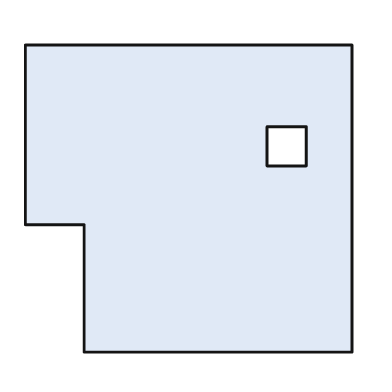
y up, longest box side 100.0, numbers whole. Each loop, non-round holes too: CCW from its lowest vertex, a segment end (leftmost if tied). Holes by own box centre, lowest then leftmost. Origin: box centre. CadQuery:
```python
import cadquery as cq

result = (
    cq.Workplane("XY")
    .moveTo(-32.0, -47.0)
    .lineTo(50.0, -47.0)
    .lineTo(50.0, 47.0)
    .lineTo(-50.0, 47.0)
    .lineTo(-50.0, -8.0)
    .lineTo(-32.0, -8.0)
    .close()
    .moveTo(24.0, 10.0)
    .lineTo(36.0, 10.0)
    .lineTo(36.0, 22.0)
    .lineTo(24.0, 22.0)
    .close()
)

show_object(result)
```